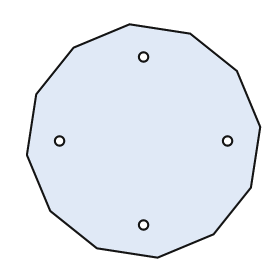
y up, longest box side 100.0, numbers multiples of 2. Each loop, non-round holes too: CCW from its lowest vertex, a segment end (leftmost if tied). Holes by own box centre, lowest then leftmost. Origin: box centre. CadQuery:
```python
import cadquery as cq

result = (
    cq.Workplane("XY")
    .moveTo(6.0, -50.0)
    .lineTo(30.0, -40.0)
    .lineTo(46.0, -20.0)
    .lineTo(50.0, 6.0)
    .lineTo(40.0, 30.0)
    .lineTo(20.0, 46.0)
    .lineTo(-6.0, 50.0)
    .lineTo(-30.0, 40.0)
    .lineTo(-46.0, 20.0)
    .lineTo(-50.0, -6.0)
    .lineTo(-40.0, -30.0)
    .lineTo(-20.0, -46.0)
    .close()
    .moveTo(0.0, -36.0)
    .circle(2.0)
    .moveTo(-36.0, 0.0)
    .circle(2.0)
    .moveTo(36.0, 0.0)
    .circle(2.0)
    .moveTo(0.0, 36.0)
    .circle(2.0)
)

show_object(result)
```